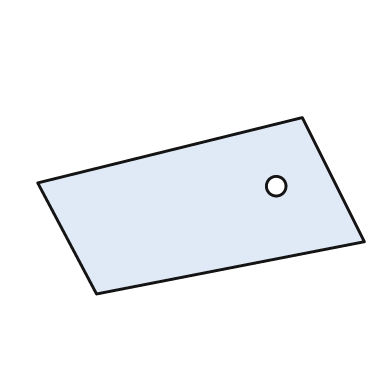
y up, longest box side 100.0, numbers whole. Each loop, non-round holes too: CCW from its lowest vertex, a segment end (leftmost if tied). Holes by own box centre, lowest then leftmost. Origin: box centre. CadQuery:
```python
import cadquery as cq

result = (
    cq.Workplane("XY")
    .moveTo(-32.0, -27.0)
    .lineTo(50.0, -11.0)
    .lineTo(31.0, 27.0)
    .lineTo(-50.0, 7.0)
    .close()
    .moveTo(23.0, 6.0)
    .circle(3.0)
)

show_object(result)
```